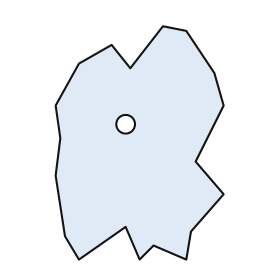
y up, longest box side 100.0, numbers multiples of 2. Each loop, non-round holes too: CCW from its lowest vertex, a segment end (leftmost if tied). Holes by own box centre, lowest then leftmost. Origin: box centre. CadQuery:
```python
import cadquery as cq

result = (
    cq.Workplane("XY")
    .moveTo(-26.0, -50.0)
    .lineTo(-6.0, -36.0)
    .lineTo(0.0, -50.0)
    .lineTo(6.0, -44.0)
    .lineTo(20.0, -50.0)
    .lineTo(22.0, -38.0)
    .lineTo(36.0, -22.0)
    .lineTo(24.0, -8.0)
    .lineTo(36.0, 16.0)
    .lineTo(32.0, 30.0)
    .lineTo(20.0, 48.0)
    .lineTo(10.0, 50.0)
    .lineTo(-4.0, 32.0)
    .lineTo(-12.0, 42.0)
    .lineTo(-26.0, 34.0)
    .lineTo(-36.0, 16.0)
    .lineTo(-34.0, 2.0)
    .lineTo(-36.0, -14.0)
    .lineTo(-32.0, -40.0)
    .close()
    .moveTo(-6.0, 8.0)
    .circle(4.0)
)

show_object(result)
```